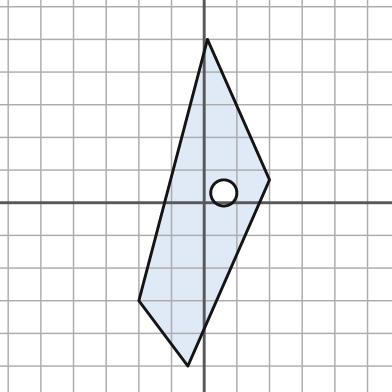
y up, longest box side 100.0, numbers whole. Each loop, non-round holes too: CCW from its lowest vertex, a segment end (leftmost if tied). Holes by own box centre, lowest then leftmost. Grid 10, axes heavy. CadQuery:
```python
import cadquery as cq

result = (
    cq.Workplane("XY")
    .moveTo(-5.0, -50.0)
    .lineTo(20.0, 7.0)
    .lineTo(1.0, 50.0)
    .lineTo(-20.0, -30.0)
    .close()
    .moveTo(6.0, 3.0)
    .circle(4.0)
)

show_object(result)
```